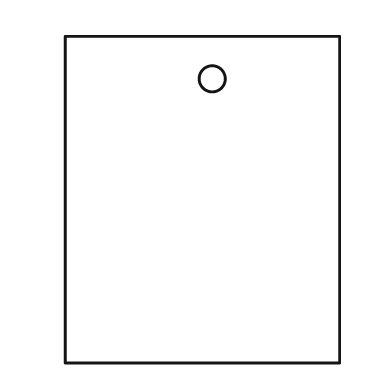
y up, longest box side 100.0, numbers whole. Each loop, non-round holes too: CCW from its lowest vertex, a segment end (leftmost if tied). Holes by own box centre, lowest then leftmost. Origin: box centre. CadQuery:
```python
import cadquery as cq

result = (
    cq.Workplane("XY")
    .moveTo(-42.0, -50.0)
    .lineTo(42.0, -50.0)
    .lineTo(42.0, 50.0)
    .lineTo(-42.0, 50.0)
    .close()
    .moveTo(3.0, 37.0)
    .circle(4.0)
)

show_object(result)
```